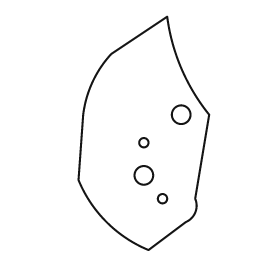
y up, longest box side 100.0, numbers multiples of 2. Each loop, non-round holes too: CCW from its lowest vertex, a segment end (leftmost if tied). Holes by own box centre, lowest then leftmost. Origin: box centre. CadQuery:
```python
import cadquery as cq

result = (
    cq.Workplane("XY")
    .moveTo(2.0, -50.0)
    .lineTo(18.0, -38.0)
    .threePointArc((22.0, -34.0), (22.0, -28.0))
    .lineTo(28.0, 8.0)
    .threePointArc((16.0, 28.0), (10.0, 50.0))
    .lineTo(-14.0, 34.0)
    .threePointArc((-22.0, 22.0), (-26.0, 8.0))
    .lineTo(-28.0, -20.0)
    .threePointArc((-16.0, -38.0), (2.0, -50.0))
    .close()
    .moveTo(8.0, -28.0)
    .circle(2.0)
    .moveTo(0.0, -18.0)
    .circle(4.0)
    .moveTo(0.0, -4.0)
    .circle(2.0)
    .moveTo(16.0, 8.0)
    .circle(4.0)
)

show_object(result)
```